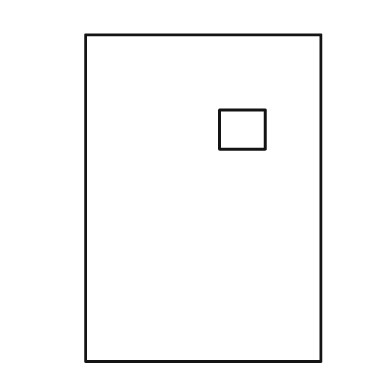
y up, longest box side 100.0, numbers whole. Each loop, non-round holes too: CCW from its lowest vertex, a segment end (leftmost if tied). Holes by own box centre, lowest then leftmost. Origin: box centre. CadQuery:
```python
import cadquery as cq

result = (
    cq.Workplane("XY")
    .moveTo(-36.0, -50.0)
    .lineTo(36.0, -50.0)
    .lineTo(36.0, 50.0)
    .lineTo(-36.0, 50.0)
    .close()
    .moveTo(5.0, 15.0)
    .lineTo(19.0, 15.0)
    .lineTo(19.0, 27.0)
    .lineTo(5.0, 27.0)
    .close()
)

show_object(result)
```